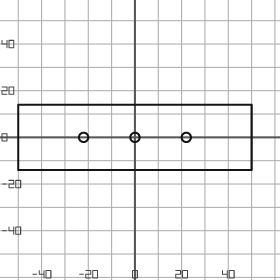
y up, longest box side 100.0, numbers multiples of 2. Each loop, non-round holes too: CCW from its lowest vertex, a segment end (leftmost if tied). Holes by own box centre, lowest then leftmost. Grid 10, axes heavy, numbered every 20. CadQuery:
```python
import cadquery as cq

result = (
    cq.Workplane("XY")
    .moveTo(-50.0, -14.0)
    .lineTo(50.0, -14.0)
    .lineTo(50.0, 14.0)
    .lineTo(-50.0, 14.0)
    .close()
    .moveTo(-22.0, 0.0)
    .circle(2.0)
    .moveTo(0.0, 0.0)
    .circle(2.0)
    .moveTo(22.0, 0.0)
    .circle(2.0)
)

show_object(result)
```